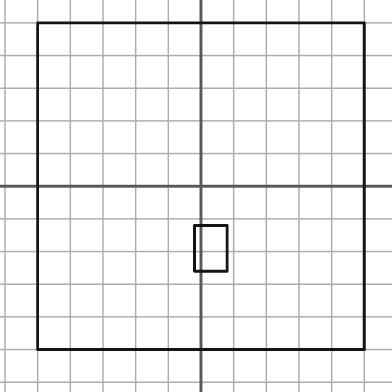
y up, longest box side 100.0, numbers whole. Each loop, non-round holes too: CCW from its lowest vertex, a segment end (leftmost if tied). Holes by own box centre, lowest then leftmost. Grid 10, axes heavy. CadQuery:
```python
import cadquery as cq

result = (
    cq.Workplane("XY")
    .moveTo(-50.0, -50.0)
    .lineTo(50.0, -50.0)
    .lineTo(50.0, 50.0)
    .lineTo(-50.0, 50.0)
    .close()
    .moveTo(-2.0, -26.0)
    .lineTo(8.0, -26.0)
    .lineTo(8.0, -12.0)
    .lineTo(-2.0, -12.0)
    .close()
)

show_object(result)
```